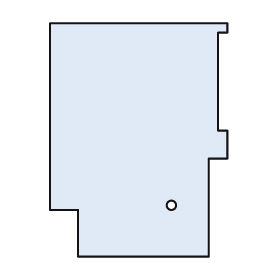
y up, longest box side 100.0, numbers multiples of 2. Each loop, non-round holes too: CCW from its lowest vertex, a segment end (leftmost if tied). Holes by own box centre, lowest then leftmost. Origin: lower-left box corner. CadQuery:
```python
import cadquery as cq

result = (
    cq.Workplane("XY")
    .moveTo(12.0, 0.0)
    .lineTo(68.0, 0.0)
    .lineTo(68.0, 42.0)
    .lineTo(76.0, 42.0)
    .lineTo(76.0, 54.0)
    .lineTo(72.0, 54.0)
    .lineTo(72.0, 96.0)
    .lineTo(76.0, 96.0)
    .lineTo(76.0, 100.0)
    .lineTo(0.0, 100.0)
    .lineTo(0.0, 20.0)
    .lineTo(12.0, 20.0)
    .close()
    .moveTo(52.0, 22.0)
    .circle(2.0)
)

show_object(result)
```